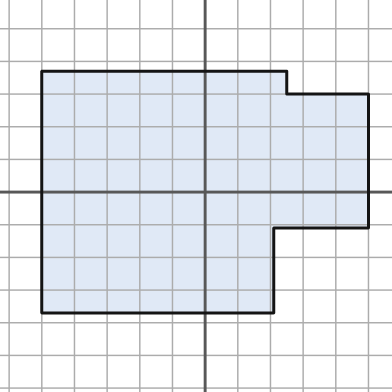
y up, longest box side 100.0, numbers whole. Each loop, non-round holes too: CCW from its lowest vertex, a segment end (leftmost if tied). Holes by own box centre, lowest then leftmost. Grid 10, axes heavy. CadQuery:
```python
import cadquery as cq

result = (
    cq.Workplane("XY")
    .moveTo(-50.0, -37.0)
    .lineTo(21.0, -37.0)
    .lineTo(21.0, -11.0)
    .lineTo(50.0, -11.0)
    .lineTo(50.0, 30.0)
    .lineTo(25.0, 30.0)
    .lineTo(25.0, 37.0)
    .lineTo(-50.0, 37.0)
    .close()
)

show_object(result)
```